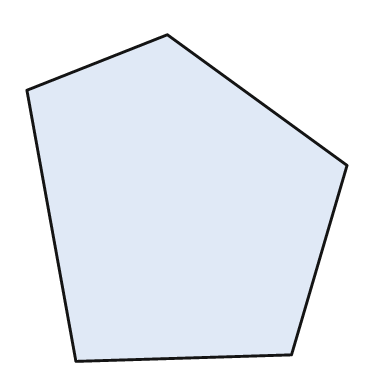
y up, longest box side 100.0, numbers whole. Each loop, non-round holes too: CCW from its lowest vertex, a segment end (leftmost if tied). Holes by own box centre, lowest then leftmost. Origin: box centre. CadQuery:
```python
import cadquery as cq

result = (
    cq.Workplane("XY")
    .moveTo(-34.0, -50.0)
    .lineTo(32.0, -48.0)
    .lineTo(49.0, 10.0)
    .lineTo(-6.0, 50.0)
    .lineTo(-49.0, 33.0)
    .close()
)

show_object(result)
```